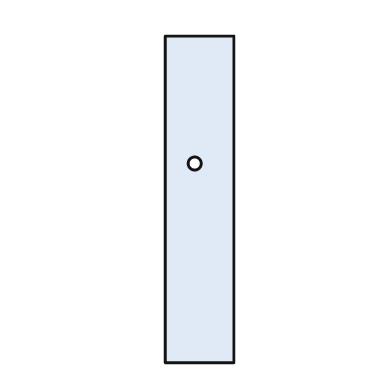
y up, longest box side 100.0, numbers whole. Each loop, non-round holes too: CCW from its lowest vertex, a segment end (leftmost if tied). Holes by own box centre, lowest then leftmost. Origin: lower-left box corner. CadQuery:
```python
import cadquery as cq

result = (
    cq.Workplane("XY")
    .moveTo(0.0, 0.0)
    .lineTo(21.0, 0.0)
    .lineTo(21.0, 100.0)
    .lineTo(0.0, 100.0)
    .close()
    .moveTo(9.0, 61.0)
    .circle(2.0)
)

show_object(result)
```